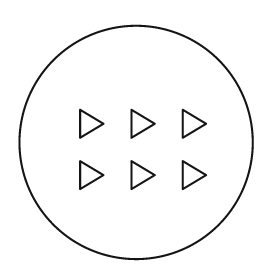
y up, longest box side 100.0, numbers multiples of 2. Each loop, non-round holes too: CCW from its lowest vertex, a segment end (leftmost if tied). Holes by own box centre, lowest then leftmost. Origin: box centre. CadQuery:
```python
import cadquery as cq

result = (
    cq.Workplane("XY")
    .moveTo(0.0, 0.0)
    .circle(50.0)
    .moveTo(-24.0, -20.0)
    .lineTo(-14.0, -14.0)
    .lineTo(-24.0, -8.0)
    .close()
    .moveTo(-2.0, -20.0)
    .lineTo(8.0, -14.0)
    .lineTo(-2.0, -8.0)
    .close()
    .moveTo(20.0, -20.0)
    .lineTo(30.0, -14.0)
    .lineTo(20.0, -8.0)
    .close()
    .moveTo(-24.0, 2.0)
    .lineTo(-14.0, 8.0)
    .lineTo(-24.0, 14.0)
    .close()
    .moveTo(-2.0, 2.0)
    .lineTo(8.0, 8.0)
    .lineTo(-2.0, 14.0)
    .close()
    .moveTo(20.0, 2.0)
    .lineTo(30.0, 8.0)
    .lineTo(20.0, 14.0)
    .close()
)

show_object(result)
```